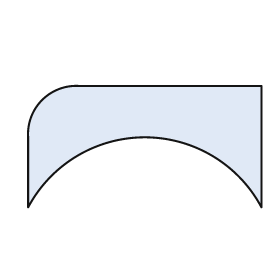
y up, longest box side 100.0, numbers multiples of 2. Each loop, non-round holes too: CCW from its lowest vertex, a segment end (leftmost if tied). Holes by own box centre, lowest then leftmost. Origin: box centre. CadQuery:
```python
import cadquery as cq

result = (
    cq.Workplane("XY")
    .moveTo(-50.0, -26.0)
    .threePointArc((0.0, 4.0), (50.0, -26.0))
    .lineTo(50.0, 26.0)
    .lineTo(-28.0, 26.0)
    .threePointArc((-44.0, 20.0), (-50.0, 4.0))
    .close()
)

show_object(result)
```